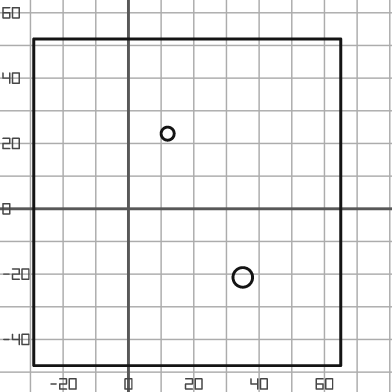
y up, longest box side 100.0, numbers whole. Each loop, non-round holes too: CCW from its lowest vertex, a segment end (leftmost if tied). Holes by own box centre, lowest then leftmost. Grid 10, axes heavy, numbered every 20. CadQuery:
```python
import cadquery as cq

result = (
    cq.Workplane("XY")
    .moveTo(-29.0, -48.0)
    .lineTo(65.0, -48.0)
    .lineTo(65.0, 52.0)
    .lineTo(-29.0, 52.0)
    .close()
    .moveTo(35.0, -21.0)
    .circle(3.0)
    .moveTo(12.0, 23.0)
    .circle(2.0)
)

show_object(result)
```